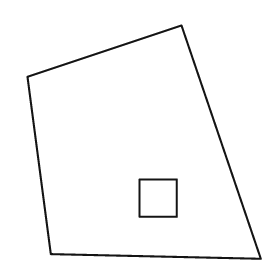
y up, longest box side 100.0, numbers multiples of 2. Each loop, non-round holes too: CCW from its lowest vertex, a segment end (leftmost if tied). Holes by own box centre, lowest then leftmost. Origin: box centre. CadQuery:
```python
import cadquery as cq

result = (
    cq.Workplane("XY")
    .moveTo(50.0, -50.0)
    .lineTo(16.0, 50.0)
    .lineTo(-50.0, 28.0)
    .lineTo(-40.0, -48.0)
    .close()
    .moveTo(-2.0, -32.0)
    .lineTo(14.0, -32.0)
    .lineTo(14.0, -16.0)
    .lineTo(-2.0, -16.0)
    .close()
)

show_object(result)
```